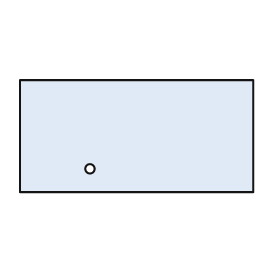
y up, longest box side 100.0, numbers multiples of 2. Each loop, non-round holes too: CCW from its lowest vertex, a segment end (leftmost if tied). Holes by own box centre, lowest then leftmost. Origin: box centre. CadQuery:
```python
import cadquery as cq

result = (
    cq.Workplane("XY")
    .moveTo(-50.0, -24.0)
    .lineTo(50.0, -24.0)
    .lineTo(50.0, 24.0)
    .lineTo(-50.0, 24.0)
    .close()
    .moveTo(-20.0, -14.0)
    .circle(2.0)
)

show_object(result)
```